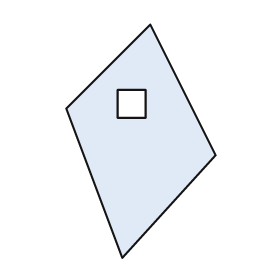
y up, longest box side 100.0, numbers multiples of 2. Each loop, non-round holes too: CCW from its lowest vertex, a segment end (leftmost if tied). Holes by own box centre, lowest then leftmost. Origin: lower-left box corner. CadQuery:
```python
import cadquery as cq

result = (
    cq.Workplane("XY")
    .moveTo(24.0, 0.0)
    .lineTo(64.0, 44.0)
    .lineTo(36.0, 100.0)
    .lineTo(0.0, 64.0)
    .close()
    .moveTo(22.0, 60.0)
    .lineTo(34.0, 60.0)
    .lineTo(34.0, 72.0)
    .lineTo(22.0, 72.0)
    .close()
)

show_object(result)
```